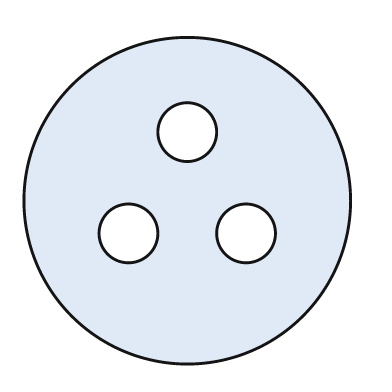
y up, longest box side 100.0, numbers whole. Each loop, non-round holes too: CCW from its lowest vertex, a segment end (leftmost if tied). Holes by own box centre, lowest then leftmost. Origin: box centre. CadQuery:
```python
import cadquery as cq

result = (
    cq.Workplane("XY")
    .moveTo(0.0, 0.0)
    .circle(50.0)
    .moveTo(-18.0, -10.0)
    .circle(9.0)
    .moveTo(18.0, -10.0)
    .circle(9.0)
    .moveTo(0.0, 21.0)
    .circle(9.0)
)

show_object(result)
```